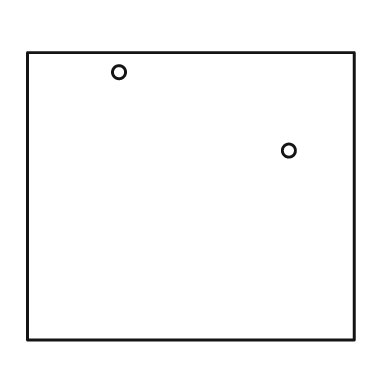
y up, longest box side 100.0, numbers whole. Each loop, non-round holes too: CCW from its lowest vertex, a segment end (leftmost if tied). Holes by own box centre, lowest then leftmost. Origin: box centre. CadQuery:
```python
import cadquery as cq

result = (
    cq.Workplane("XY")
    .moveTo(-50.0, -44.0)
    .lineTo(50.0, -44.0)
    .lineTo(50.0, 44.0)
    .lineTo(-50.0, 44.0)
    .close()
    .moveTo(30.0, 14.0)
    .circle(2.0)
    .moveTo(-22.0, 38.0)
    .circle(2.0)
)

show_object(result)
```